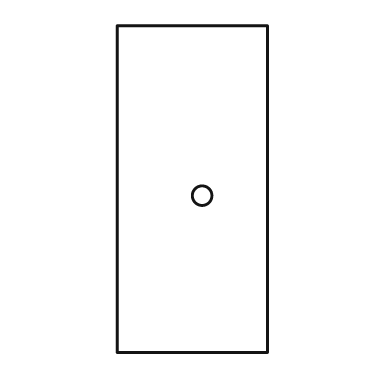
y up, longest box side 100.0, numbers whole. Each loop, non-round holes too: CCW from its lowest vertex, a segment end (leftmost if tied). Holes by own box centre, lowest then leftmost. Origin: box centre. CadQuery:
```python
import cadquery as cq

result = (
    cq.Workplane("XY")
    .moveTo(-23.0, -50.0)
    .lineTo(23.0, -50.0)
    .lineTo(23.0, 50.0)
    .lineTo(-23.0, 50.0)
    .close()
    .moveTo(3.0, -2.0)
    .circle(3.0)
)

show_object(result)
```